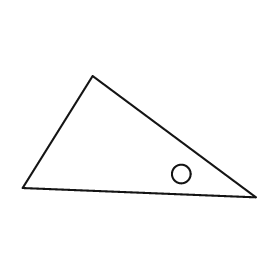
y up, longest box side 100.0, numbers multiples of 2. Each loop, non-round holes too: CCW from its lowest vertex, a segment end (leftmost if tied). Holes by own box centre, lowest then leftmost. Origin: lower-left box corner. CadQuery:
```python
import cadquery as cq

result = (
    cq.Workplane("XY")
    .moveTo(100.0, 0.0)
    .lineTo(30.0, 52.0)
    .lineTo(0.0, 4.0)
    .close()
    .moveTo(68.0, 10.0)
    .circle(4.0)
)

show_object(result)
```